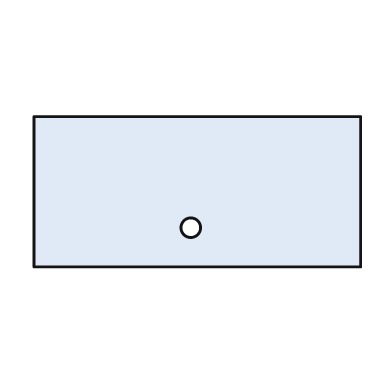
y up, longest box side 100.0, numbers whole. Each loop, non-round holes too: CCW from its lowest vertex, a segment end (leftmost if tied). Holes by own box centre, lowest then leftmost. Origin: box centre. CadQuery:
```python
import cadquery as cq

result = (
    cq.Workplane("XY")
    .moveTo(-50.0, -23.0)
    .lineTo(50.0, -23.0)
    .lineTo(50.0, 23.0)
    .lineTo(-50.0, 23.0)
    .close()
    .moveTo(-2.0, -11.0)
    .circle(3.0)
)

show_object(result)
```